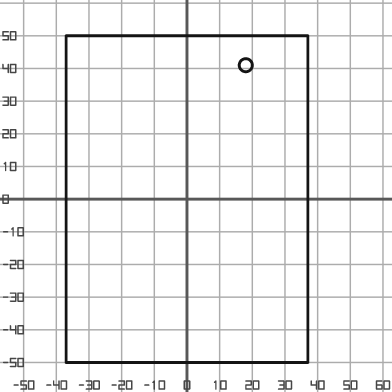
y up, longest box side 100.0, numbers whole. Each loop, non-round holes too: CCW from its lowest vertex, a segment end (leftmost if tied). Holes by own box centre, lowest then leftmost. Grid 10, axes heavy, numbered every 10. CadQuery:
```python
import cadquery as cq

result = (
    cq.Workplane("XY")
    .moveTo(-37.0, -50.0)
    .lineTo(37.0, -50.0)
    .lineTo(37.0, 50.0)
    .lineTo(-37.0, 50.0)
    .close()
    .moveTo(18.0, 41.0)
    .circle(2.0)
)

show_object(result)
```